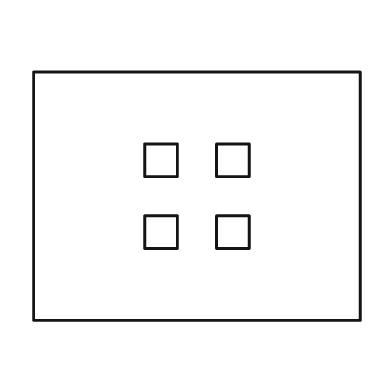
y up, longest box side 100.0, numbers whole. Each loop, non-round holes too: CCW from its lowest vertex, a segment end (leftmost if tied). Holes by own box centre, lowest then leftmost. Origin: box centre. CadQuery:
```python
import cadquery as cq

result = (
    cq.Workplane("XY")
    .moveTo(-50.0, -38.0)
    .lineTo(50.0, -38.0)
    .lineTo(50.0, 38.0)
    .lineTo(-50.0, 38.0)
    .close()
    .moveTo(-16.0, -16.0)
    .lineTo(-6.0, -16.0)
    .lineTo(-6.0, -6.0)
    .lineTo(-16.0, -6.0)
    .close()
    .moveTo(6.0, -16.0)
    .lineTo(16.0, -16.0)
    .lineTo(16.0, -6.0)
    .lineTo(6.0, -6.0)
    .close()
    .moveTo(-16.0, 6.0)
    .lineTo(-6.0, 6.0)
    .lineTo(-6.0, 16.0)
    .lineTo(-16.0, 16.0)
    .close()
    .moveTo(6.0, 6.0)
    .lineTo(16.0, 6.0)
    .lineTo(16.0, 16.0)
    .lineTo(6.0, 16.0)
    .close()
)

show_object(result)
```